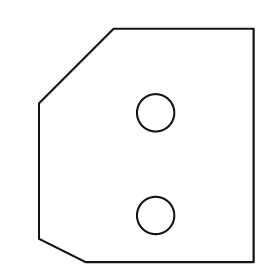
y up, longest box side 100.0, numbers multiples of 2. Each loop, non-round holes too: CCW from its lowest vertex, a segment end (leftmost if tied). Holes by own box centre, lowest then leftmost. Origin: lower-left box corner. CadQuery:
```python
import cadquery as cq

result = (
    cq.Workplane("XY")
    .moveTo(20.0, 0.0)
    .lineTo(92.0, 0.0)
    .lineTo(92.0, 100.0)
    .lineTo(32.0, 100.0)
    .lineTo(0.0, 68.0)
    .lineTo(0.0, 10.0)
    .close()
    .moveTo(50.0, 20.0)
    .circle(8.0)
    .moveTo(50.0, 64.0)
    .circle(8.0)
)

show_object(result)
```